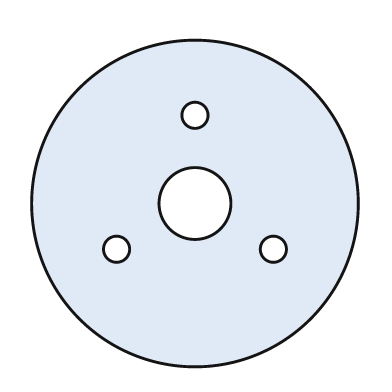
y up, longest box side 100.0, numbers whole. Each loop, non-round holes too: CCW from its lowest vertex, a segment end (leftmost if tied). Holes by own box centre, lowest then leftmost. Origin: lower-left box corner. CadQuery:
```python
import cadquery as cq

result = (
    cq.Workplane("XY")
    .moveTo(50.0, 50.0)
    .circle(50.0)
    .moveTo(26.0, 36.0)
    .circle(4.0)
    .moveTo(74.0, 36.0)
    .circle(4.0)
    .moveTo(50.0, 50.0)
    .circle(11.0)
    .moveTo(50.0, 77.0)
    .circle(4.0)
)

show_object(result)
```